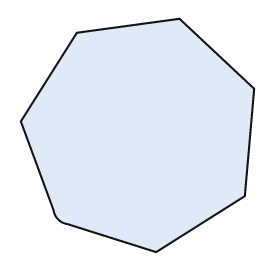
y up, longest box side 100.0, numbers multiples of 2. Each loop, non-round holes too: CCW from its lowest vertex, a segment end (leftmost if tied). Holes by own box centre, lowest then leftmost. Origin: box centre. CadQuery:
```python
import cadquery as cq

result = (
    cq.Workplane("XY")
    .moveTo(8.0, -50.0)
    .lineTo(46.0, -26.0)
    .lineTo(50.0, 20.0)
    .lineTo(18.0, 50.0)
    .lineTo(-26.0, 44.0)
    .lineTo(-50.0, 6.0)
    .lineTo(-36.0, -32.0)
    .threePointArc((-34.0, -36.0), (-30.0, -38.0))
    .close()
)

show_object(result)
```